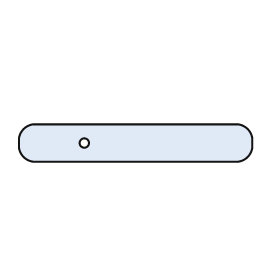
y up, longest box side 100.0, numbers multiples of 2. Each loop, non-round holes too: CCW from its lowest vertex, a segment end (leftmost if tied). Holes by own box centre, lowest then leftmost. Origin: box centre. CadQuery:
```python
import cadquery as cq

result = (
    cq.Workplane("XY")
    .moveTo(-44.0, -8.0)
    .lineTo(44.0, -8.0)
    .threePointArc((48.0, -6.0), (50.0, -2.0))
    .lineTo(50.0, 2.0)
    .threePointArc((48.0, 6.0), (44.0, 8.0))
    .lineTo(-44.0, 8.0)
    .threePointArc((-48.0, 6.0), (-50.0, 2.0))
    .lineTo(-50.0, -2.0)
    .threePointArc((-48.0, -6.0), (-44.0, -8.0))
    .close()
    .moveTo(-22.0, 0.0)
    .circle(2.0)
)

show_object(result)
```